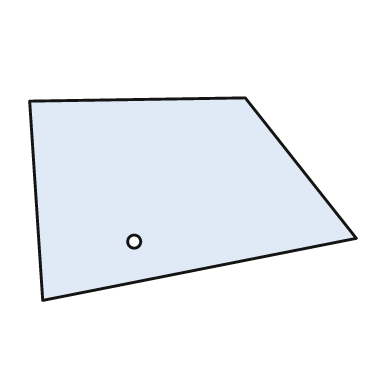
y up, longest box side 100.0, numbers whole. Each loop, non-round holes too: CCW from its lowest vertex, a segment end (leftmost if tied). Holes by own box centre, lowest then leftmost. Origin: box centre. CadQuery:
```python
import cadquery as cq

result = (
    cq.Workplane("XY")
    .moveTo(-46.0, -31.0)
    .lineTo(50.0, -12.0)
    .lineTo(16.0, 31.0)
    .lineTo(-50.0, 30.0)
    .close()
    .moveTo(-18.0, -13.0)
    .circle(2.0)
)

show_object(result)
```